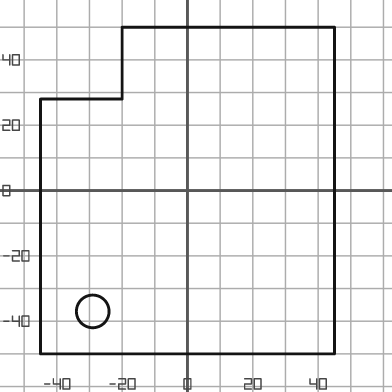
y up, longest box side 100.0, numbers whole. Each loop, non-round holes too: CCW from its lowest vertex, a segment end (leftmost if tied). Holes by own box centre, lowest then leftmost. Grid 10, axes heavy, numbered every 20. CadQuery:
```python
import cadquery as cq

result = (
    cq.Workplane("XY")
    .moveTo(-45.0, -50.0)
    .lineTo(45.0, -50.0)
    .lineTo(45.0, 50.0)
    .lineTo(-20.0, 50.0)
    .lineTo(-20.0, 28.0)
    .lineTo(-45.0, 28.0)
    .close()
    .moveTo(-29.0, -37.0)
    .circle(5.0)
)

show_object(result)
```